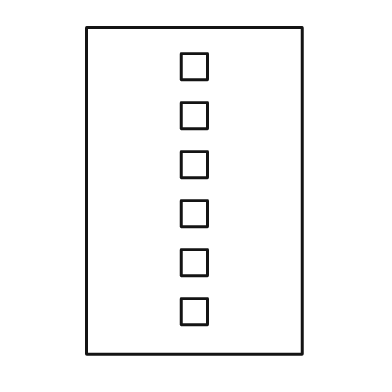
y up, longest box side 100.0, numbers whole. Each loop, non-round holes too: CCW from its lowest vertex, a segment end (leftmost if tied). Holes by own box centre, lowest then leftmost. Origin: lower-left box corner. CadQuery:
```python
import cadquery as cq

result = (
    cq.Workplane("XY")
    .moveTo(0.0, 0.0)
    .lineTo(66.0, 0.0)
    .lineTo(66.0, 100.0)
    .lineTo(0.0, 100.0)
    .close()
    .moveTo(29.0, 9.0)
    .lineTo(37.0, 9.0)
    .lineTo(37.0, 17.0)
    .lineTo(29.0, 17.0)
    .close()
    .moveTo(29.0, 24.0)
    .lineTo(37.0, 24.0)
    .lineTo(37.0, 32.0)
    .lineTo(29.0, 32.0)
    .close()
    .moveTo(29.0, 39.0)
    .lineTo(37.0, 39.0)
    .lineTo(37.0, 47.0)
    .lineTo(29.0, 47.0)
    .close()
    .moveTo(29.0, 54.0)
    .lineTo(37.0, 54.0)
    .lineTo(37.0, 62.0)
    .lineTo(29.0, 62.0)
    .close()
    .moveTo(29.0, 69.0)
    .lineTo(37.0, 69.0)
    .lineTo(37.0, 77.0)
    .lineTo(29.0, 77.0)
    .close()
    .moveTo(29.0, 84.0)
    .lineTo(37.0, 84.0)
    .lineTo(37.0, 92.0)
    .lineTo(29.0, 92.0)
    .close()
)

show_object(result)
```